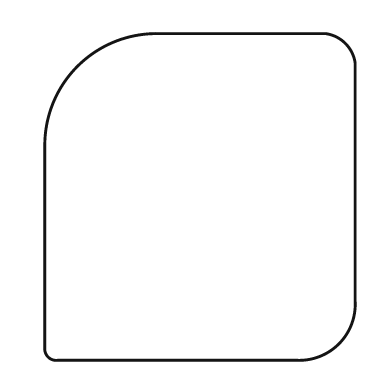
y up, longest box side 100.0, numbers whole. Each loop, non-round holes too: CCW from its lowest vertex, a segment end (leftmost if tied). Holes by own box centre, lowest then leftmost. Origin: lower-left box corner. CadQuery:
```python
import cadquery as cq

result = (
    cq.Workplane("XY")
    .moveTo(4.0, 0.0)
    .lineTo(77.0, 0.0)
    .threePointArc((90.0, 5.0), (95.0, 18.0))
    .lineTo(95.0, 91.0)
    .threePointArc((92.0, 97.0), (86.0, 100.0))
    .lineTo(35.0, 100.0)
    .threePointArc((10.0, 90.0), (0.0, 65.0))
    .lineTo(0.0, 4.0)
    .threePointArc((1.0, 1.0), (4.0, 0.0))
    .close()
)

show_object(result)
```